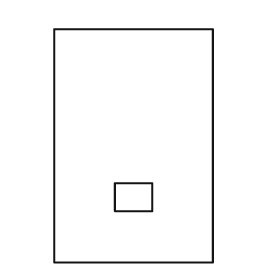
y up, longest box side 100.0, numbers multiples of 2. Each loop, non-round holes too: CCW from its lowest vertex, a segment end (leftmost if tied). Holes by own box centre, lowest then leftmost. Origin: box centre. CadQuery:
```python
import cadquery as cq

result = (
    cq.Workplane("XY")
    .moveTo(-34.0, -50.0)
    .lineTo(34.0, -50.0)
    .lineTo(34.0, 50.0)
    .lineTo(-34.0, 50.0)
    .close()
    .moveTo(-8.0, -28.0)
    .lineTo(8.0, -28.0)
    .lineTo(8.0, -16.0)
    .lineTo(-8.0, -16.0)
    .close()
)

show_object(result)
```